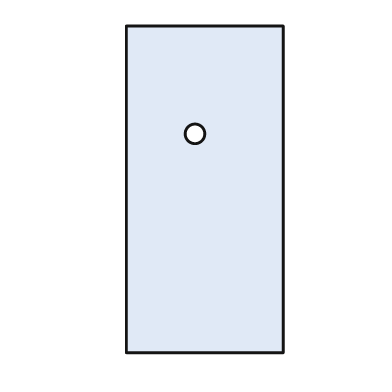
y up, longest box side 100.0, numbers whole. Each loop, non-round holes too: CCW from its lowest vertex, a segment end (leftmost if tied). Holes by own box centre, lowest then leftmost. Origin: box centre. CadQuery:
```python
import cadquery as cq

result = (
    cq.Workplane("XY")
    .moveTo(-24.0, -50.0)
    .lineTo(24.0, -50.0)
    .lineTo(24.0, 50.0)
    .lineTo(-24.0, 50.0)
    .close()
    .moveTo(-3.0, 17.0)
    .circle(3.0)
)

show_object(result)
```